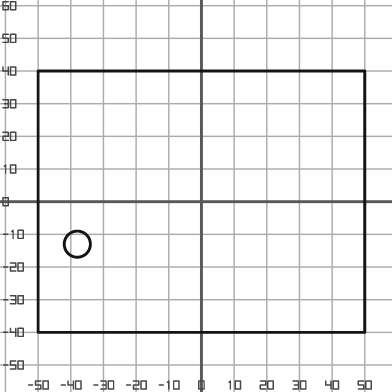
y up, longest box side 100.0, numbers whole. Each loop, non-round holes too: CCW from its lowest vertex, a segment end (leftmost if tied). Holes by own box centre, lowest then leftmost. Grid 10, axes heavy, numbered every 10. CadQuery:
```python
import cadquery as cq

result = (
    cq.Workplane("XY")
    .moveTo(-50.0, -40.0)
    .lineTo(50.0, -40.0)
    .lineTo(50.0, 40.0)
    .lineTo(-50.0, 40.0)
    .close()
    .moveTo(-38.0, -13.0)
    .circle(4.0)
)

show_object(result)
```